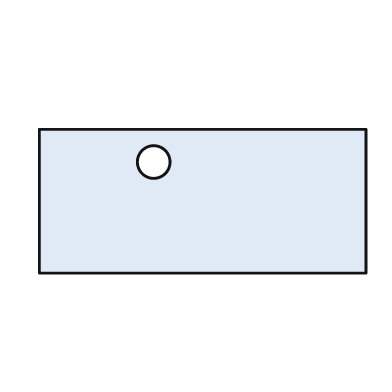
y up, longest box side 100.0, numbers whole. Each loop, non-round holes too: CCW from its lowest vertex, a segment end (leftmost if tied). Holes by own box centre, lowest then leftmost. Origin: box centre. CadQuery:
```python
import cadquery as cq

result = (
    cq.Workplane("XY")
    .moveTo(-50.0, -22.0)
    .lineTo(50.0, -22.0)
    .lineTo(50.0, 22.0)
    .lineTo(-50.0, 22.0)
    .close()
    .moveTo(-15.0, 12.0)
    .circle(5.0)
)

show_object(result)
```